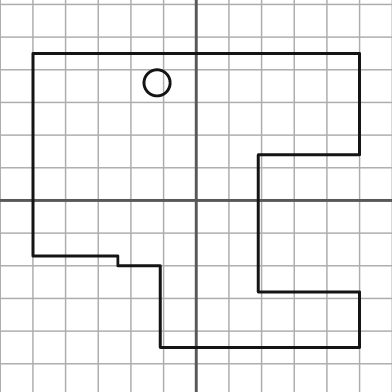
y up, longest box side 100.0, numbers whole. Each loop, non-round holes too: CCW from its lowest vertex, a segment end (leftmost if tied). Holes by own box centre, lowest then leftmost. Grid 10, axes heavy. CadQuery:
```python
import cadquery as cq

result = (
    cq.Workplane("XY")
    .moveTo(-11.0, -45.0)
    .lineTo(50.0, -45.0)
    .lineTo(50.0, -28.0)
    .lineTo(19.0, -28.0)
    .lineTo(19.0, 14.0)
    .lineTo(50.0, 14.0)
    .lineTo(50.0, 45.0)
    .lineTo(-50.0, 45.0)
    .lineTo(-50.0, -17.0)
    .lineTo(-24.0, -17.0)
    .lineTo(-24.0, -20.0)
    .lineTo(-11.0, -20.0)
    .close()
    .moveTo(-12.0, 36.0)
    .circle(4.0)
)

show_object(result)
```